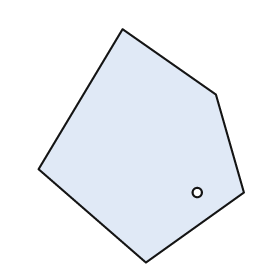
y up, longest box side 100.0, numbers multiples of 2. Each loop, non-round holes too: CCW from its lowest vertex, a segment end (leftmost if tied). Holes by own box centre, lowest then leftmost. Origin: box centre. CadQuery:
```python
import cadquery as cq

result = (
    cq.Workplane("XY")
    .moveTo(2.0, -50.0)
    .lineTo(44.0, -20.0)
    .lineTo(32.0, 22.0)
    .lineTo(-8.0, 50.0)
    .lineTo(-44.0, -10.0)
    .close()
    .moveTo(24.0, -20.0)
    .circle(2.0)
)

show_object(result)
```